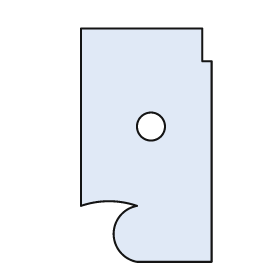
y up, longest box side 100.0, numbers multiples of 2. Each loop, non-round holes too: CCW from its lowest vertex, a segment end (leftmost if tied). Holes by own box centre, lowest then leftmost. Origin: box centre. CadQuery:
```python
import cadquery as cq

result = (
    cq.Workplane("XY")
    .moveTo(-4.0, -50.0)
    .lineTo(28.0, -50.0)
    .lineTo(28.0, 36.0)
    .lineTo(24.0, 36.0)
    .lineTo(24.0, 50.0)
    .lineTo(-28.0, 50.0)
    .lineTo(-28.0, -26.0)
    .threePointArc((-16.0, -24.0), (-4.0, -26.0))
    .threePointArc((-14.0, -38.0), (-4.0, -50.0))
    .close()
    .moveTo(2.0, 8.0)
    .circle(6.0)
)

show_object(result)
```